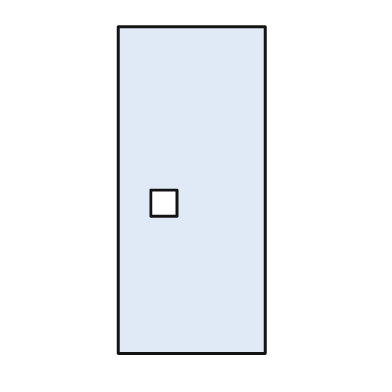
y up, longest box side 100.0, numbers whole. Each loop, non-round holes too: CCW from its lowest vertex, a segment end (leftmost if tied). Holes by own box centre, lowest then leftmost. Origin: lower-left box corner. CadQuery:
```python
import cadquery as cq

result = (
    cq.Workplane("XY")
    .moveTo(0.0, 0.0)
    .lineTo(45.0, 0.0)
    .lineTo(45.0, 100.0)
    .lineTo(0.0, 100.0)
    .close()
    .moveTo(10.0, 42.0)
    .lineTo(18.0, 42.0)
    .lineTo(18.0, 50.0)
    .lineTo(10.0, 50.0)
    .close()
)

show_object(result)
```